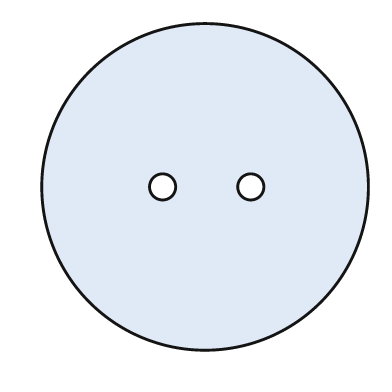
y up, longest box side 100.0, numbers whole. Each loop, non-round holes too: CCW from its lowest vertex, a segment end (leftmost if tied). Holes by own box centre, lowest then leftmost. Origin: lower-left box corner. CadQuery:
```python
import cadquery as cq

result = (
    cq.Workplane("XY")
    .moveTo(50.0, 50.0)
    .circle(50.0)
    .moveTo(37.0, 50.0)
    .circle(4.0)
    .moveTo(64.0, 50.0)
    .circle(4.0)
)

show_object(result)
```